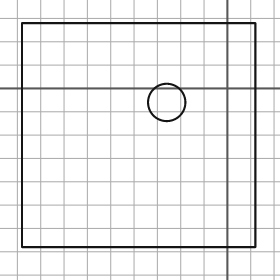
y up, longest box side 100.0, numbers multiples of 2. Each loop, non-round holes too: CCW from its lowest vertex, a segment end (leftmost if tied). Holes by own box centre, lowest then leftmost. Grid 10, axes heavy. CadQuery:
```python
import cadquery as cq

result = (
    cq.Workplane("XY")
    .moveTo(-88.0, -68.0)
    .lineTo(12.0, -68.0)
    .lineTo(12.0, 28.0)
    .lineTo(-88.0, 28.0)
    .close()
    .moveTo(-26.0, -6.0)
    .circle(8.0)
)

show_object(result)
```